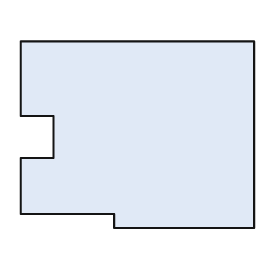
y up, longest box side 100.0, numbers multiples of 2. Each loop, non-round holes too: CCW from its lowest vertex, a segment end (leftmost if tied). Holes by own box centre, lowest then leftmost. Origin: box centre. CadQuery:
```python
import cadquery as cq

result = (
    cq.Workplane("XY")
    .moveTo(-10.0, -40.0)
    .lineTo(50.0, -40.0)
    .lineTo(50.0, 40.0)
    .lineTo(-50.0, 40.0)
    .lineTo(-50.0, 8.0)
    .lineTo(-36.0, 8.0)
    .lineTo(-36.0, -10.0)
    .lineTo(-50.0, -10.0)
    .lineTo(-50.0, -34.0)
    .lineTo(-10.0, -34.0)
    .close()
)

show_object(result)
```